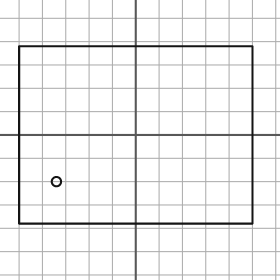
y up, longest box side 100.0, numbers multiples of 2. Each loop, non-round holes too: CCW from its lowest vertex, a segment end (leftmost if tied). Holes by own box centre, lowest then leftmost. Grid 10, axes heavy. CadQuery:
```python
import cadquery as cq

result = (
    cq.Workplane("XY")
    .moveTo(-50.0, -38.0)
    .lineTo(50.0, -38.0)
    .lineTo(50.0, 38.0)
    .lineTo(-50.0, 38.0)
    .close()
    .moveTo(-34.0, -20.0)
    .circle(2.0)
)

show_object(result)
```